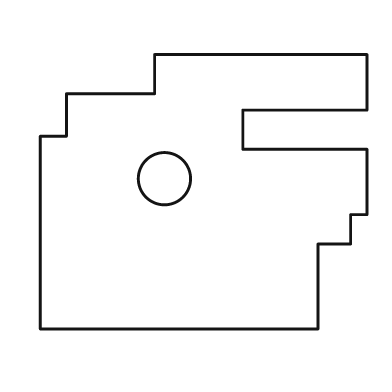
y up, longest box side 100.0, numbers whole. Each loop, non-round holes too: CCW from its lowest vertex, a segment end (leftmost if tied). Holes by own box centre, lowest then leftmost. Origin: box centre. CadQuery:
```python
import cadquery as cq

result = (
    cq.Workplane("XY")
    .moveTo(-50.0, -42.0)
    .lineTo(35.0, -42.0)
    .lineTo(35.0, -16.0)
    .lineTo(45.0, -16.0)
    .lineTo(45.0, -7.0)
    .lineTo(50.0, -7.0)
    .lineTo(50.0, 13.0)
    .lineTo(12.0, 13.0)
    .lineTo(12.0, 25.0)
    .lineTo(50.0, 25.0)
    .lineTo(50.0, 42.0)
    .lineTo(-15.0, 42.0)
    .lineTo(-15.0, 30.0)
    .lineTo(-42.0, 30.0)
    .lineTo(-42.0, 17.0)
    .lineTo(-50.0, 17.0)
    .close()
    .moveTo(-12.0, 4.0)
    .circle(8.0)
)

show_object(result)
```